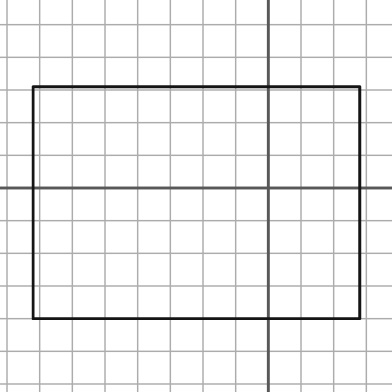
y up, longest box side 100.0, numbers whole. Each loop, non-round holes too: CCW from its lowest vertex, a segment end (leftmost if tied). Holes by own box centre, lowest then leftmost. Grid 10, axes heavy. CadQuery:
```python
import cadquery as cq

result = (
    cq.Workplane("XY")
    .moveTo(-72.0, -40.0)
    .lineTo(28.0, -40.0)
    .lineTo(28.0, 31.0)
    .lineTo(-72.0, 31.0)
    .close()
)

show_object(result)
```